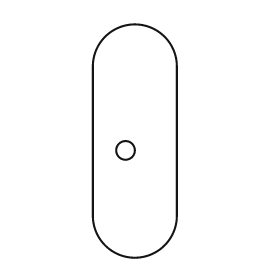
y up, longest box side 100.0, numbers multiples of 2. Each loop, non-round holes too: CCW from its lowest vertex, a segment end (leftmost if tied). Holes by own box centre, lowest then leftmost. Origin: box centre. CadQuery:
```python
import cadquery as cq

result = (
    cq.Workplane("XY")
    .moveTo(-18.0, -32.0)
    .threePointArc((0.0, -50.0), (18.0, -32.0))
    .lineTo(18.0, 32.0)
    .threePointArc((0.0, 50.0), (-18.0, 32.0))
    .close()
    .moveTo(-4.0, -4.0)
    .circle(4.0)
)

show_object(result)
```